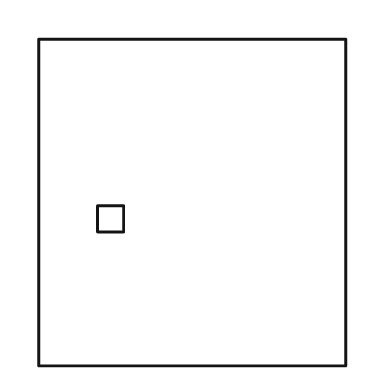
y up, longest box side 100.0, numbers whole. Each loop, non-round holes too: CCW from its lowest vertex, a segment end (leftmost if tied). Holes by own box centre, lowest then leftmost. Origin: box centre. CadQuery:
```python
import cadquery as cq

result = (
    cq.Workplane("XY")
    .moveTo(-47.0, -50.0)
    .lineTo(47.0, -50.0)
    .lineTo(47.0, 50.0)
    .lineTo(-47.0, 50.0)
    .close()
    .moveTo(-29.0, -9.0)
    .lineTo(-21.0, -9.0)
    .lineTo(-21.0, -1.0)
    .lineTo(-29.0, -1.0)
    .close()
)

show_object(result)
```